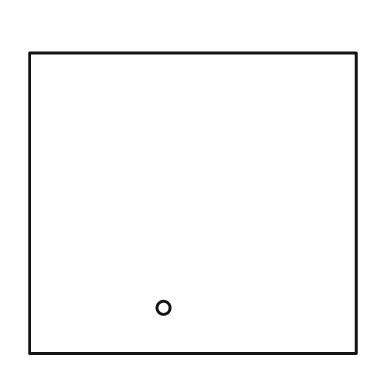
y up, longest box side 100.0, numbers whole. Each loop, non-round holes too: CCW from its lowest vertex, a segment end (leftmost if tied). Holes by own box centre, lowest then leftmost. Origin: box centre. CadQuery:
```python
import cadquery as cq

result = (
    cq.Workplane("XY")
    .moveTo(-50.0, -46.0)
    .lineTo(50.0, -46.0)
    .lineTo(50.0, 46.0)
    .lineTo(-50.0, 46.0)
    .close()
    .moveTo(-9.0, -32.0)
    .circle(2.0)
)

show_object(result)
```